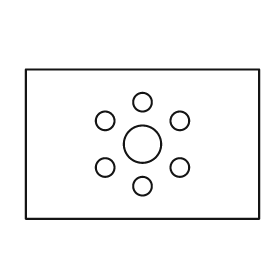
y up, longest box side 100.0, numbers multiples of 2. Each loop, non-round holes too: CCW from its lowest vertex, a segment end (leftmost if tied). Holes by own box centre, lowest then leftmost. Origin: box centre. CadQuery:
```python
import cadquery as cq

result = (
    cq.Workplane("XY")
    .moveTo(-50.0, -32.0)
    .lineTo(50.0, -32.0)
    .lineTo(50.0, 32.0)
    .lineTo(-50.0, 32.0)
    .close()
    .moveTo(0.0, -18.0)
    .circle(4.0)
    .moveTo(-16.0, -10.0)
    .circle(4.0)
    .moveTo(16.0, -10.0)
    .circle(4.0)
    .moveTo(0.0, 0.0)
    .circle(8.0)
    .moveTo(-16.0, 10.0)
    .circle(4.0)
    .moveTo(16.0, 10.0)
    .circle(4.0)
    .moveTo(0.0, 18.0)
    .circle(4.0)
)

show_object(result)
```